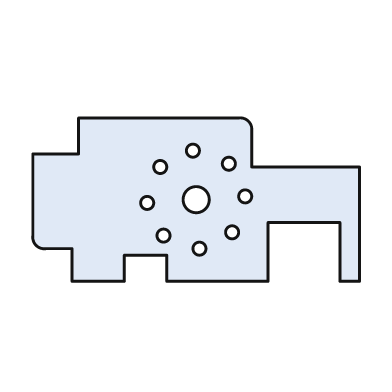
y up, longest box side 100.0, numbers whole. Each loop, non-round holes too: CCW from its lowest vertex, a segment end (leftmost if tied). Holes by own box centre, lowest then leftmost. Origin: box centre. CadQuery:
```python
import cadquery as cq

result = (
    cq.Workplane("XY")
    .moveTo(-38.0, -25.0)
    .lineTo(-22.0, -25.0)
    .lineTo(-22.0, -17.0)
    .lineTo(-9.0, -17.0)
    .lineTo(-9.0, -25.0)
    .lineTo(22.0, -25.0)
    .lineTo(22.0, -7.0)
    .lineTo(44.0, -7.0)
    .lineTo(44.0, -25.0)
    .lineTo(50.0, -25.0)
    .lineTo(50.0, 10.0)
    .lineTo(17.0, 10.0)
    .lineTo(17.0, 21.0)
    .threePointArc((16.0, 24.0), (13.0, 25.0))
    .lineTo(-36.0, 25.0)
    .lineTo(-36.0, 14.0)
    .lineTo(-50.0, 14.0)
    .lineTo(-50.0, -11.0)
    .threePointArc((-49.0, -14.0), (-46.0, -15.0))
    .lineTo(-38.0, -15.0)
    .close()
    .moveTo(1.0, -15.0)
    .circle(2.0)
    .moveTo(-10.0, -11.0)
    .circle(2.0)
    .moveTo(11.0, -10.0)
    .circle(2.0)
    .moveTo(-15.0, -1.0)
    .circle(2.0)
    .moveTo(0.0, 0.0)
    .circle(4.0)
    .moveTo(15.0, 1.0)
    .circle(2.0)
    .moveTo(-11.0, 10.0)
    .circle(2.0)
    .moveTo(10.0, 11.0)
    .circle(2.0)
    .moveTo(-1.0, 15.0)
    .circle(2.0)
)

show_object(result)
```